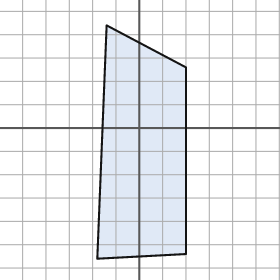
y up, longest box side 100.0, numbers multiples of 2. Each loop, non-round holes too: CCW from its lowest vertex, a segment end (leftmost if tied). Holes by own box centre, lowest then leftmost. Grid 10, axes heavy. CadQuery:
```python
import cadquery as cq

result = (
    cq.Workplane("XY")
    .moveTo(-18.0, -56.0)
    .lineTo(20.0, -54.0)
    .lineTo(20.0, 26.0)
    .lineTo(-14.0, 44.0)
    .close()
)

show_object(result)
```